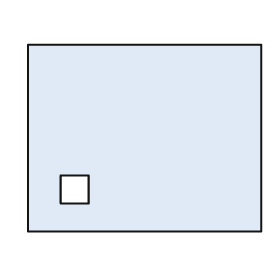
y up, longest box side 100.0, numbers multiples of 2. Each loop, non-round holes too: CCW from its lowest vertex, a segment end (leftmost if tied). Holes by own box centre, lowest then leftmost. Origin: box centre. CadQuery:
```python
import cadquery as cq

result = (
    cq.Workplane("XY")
    .moveTo(-50.0, -40.0)
    .lineTo(50.0, -40.0)
    .lineTo(50.0, 40.0)
    .lineTo(-50.0, 40.0)
    .close()
    .moveTo(-36.0, -28.0)
    .lineTo(-24.0, -28.0)
    .lineTo(-24.0, -16.0)
    .lineTo(-36.0, -16.0)
    .close()
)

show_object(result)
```